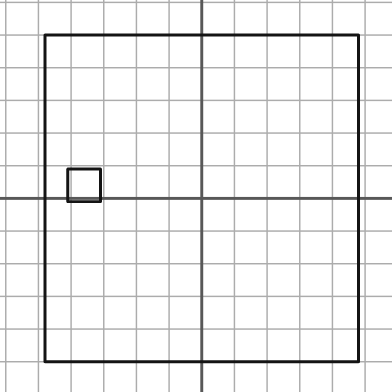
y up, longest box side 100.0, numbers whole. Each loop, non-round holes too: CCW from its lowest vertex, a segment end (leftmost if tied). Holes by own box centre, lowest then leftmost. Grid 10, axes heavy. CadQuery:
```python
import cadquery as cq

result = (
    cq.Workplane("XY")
    .moveTo(-48.0, -50.0)
    .lineTo(48.0, -50.0)
    .lineTo(48.0, 50.0)
    .lineTo(-48.0, 50.0)
    .close()
    .moveTo(-41.0, -1.0)
    .lineTo(-31.0, -1.0)
    .lineTo(-31.0, 9.0)
    .lineTo(-41.0, 9.0)
    .close()
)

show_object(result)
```